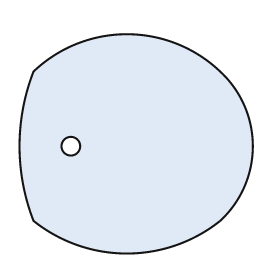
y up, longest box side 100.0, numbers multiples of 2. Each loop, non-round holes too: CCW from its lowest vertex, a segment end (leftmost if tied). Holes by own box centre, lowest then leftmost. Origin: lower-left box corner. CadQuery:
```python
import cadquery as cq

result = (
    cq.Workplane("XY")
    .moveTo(6.0, 14.0)
    .threePointArc((46.0, 0.0), (86.0, 14.0))
    .threePointArc((100.0, 46.0), (86.0, 78.0))
    .threePointArc((46.0, 94.0), (6.0, 78.0))
    .threePointArc((0.0, 46.0), (6.0, 14.0))
    .close()
    .moveTo(22.0, 46.0)
    .circle(4.0)
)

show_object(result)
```